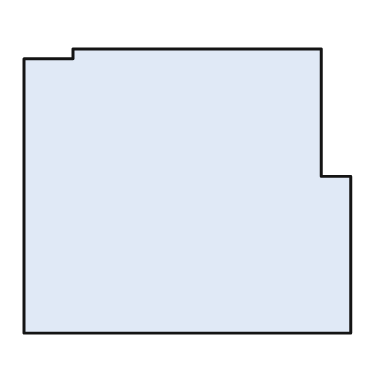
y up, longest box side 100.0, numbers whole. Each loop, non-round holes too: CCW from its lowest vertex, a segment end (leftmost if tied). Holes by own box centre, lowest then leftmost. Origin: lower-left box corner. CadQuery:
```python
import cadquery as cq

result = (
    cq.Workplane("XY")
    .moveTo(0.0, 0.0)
    .lineTo(100.0, 0.0)
    .lineTo(100.0, 48.0)
    .lineTo(91.0, 48.0)
    .lineTo(91.0, 87.0)
    .lineTo(15.0, 87.0)
    .lineTo(15.0, 84.0)
    .lineTo(0.0, 84.0)
    .close()
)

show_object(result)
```